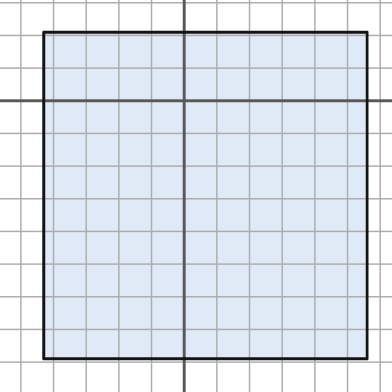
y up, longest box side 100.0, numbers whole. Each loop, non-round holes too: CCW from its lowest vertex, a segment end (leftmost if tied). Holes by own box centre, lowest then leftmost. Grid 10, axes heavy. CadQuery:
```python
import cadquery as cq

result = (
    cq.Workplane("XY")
    .moveTo(-43.0, -79.0)
    .lineTo(56.0, -79.0)
    .lineTo(56.0, 21.0)
    .lineTo(-43.0, 21.0)
    .close()
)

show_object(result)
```